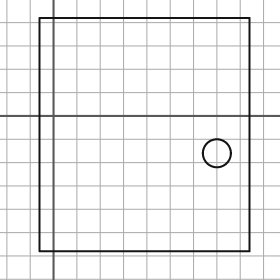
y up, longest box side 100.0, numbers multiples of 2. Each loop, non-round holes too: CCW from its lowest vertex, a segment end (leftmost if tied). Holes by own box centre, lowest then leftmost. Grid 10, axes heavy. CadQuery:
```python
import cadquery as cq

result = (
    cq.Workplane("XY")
    .moveTo(-6.0, -58.0)
    .lineTo(84.0, -58.0)
    .lineTo(84.0, 42.0)
    .lineTo(-6.0, 42.0)
    .close()
    .moveTo(70.0, -16.0)
    .circle(6.0)
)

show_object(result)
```